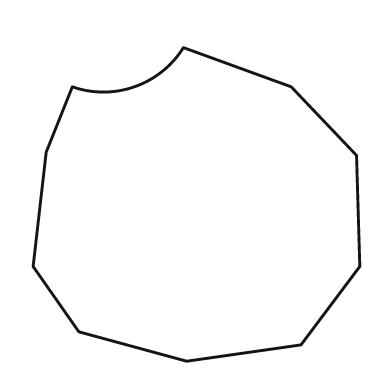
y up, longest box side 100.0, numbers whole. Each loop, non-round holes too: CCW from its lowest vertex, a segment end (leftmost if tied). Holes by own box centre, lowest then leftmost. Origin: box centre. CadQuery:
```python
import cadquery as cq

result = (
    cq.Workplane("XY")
    .moveTo(-3.0, -48.0)
    .lineTo(32.0, -43.0)
    .lineTo(50.0, -19.0)
    .lineTo(49.0, 15.0)
    .lineTo(29.0, 36.0)
    .lineTo(-4.0, 48.0)
    .threePointArc((-19.0, 36.0), (-38.0, 36.0))
    .lineTo(-46.0, 16.0)
    .lineTo(-50.0, -19.0)
    .lineTo(-36.0, -39.0)
    .close()
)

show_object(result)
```